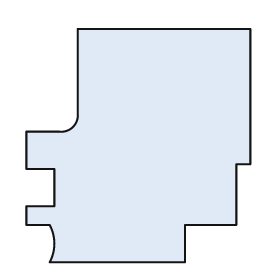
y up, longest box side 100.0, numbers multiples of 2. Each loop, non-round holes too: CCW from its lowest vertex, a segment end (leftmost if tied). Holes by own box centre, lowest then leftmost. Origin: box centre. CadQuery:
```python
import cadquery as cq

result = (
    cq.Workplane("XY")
    .moveTo(-38.0, -50.0)
    .lineTo(20.0, -50.0)
    .lineTo(20.0, -34.0)
    .lineTo(42.0, -34.0)
    .lineTo(42.0, -8.0)
    .lineTo(48.0, -8.0)
    .lineTo(48.0, 50.0)
    .lineTo(-26.0, 50.0)
    .lineTo(-26.0, 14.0)
    .threePointArc((-28.0, 8.0), (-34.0, 6.0))
    .lineTo(-48.0, 6.0)
    .lineTo(-48.0, -10.0)
    .lineTo(-36.0, -10.0)
    .lineTo(-36.0, -26.0)
    .lineTo(-48.0, -26.0)
    .lineTo(-48.0, -34.0)
    .lineTo(-38.0, -34.0)
    .threePointArc((-36.0, -42.0), (-38.0, -50.0))
    .close()
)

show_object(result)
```